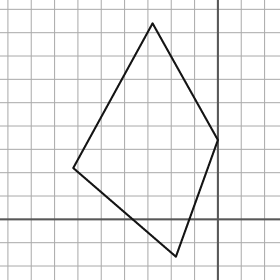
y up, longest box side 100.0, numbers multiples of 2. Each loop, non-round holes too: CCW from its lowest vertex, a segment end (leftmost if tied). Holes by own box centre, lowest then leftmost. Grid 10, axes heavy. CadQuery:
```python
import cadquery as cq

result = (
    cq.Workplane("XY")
    .moveTo(-18.0, -16.0)
    .lineTo(0.0, 34.0)
    .lineTo(-28.0, 84.0)
    .lineTo(-62.0, 22.0)
    .close()
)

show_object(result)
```